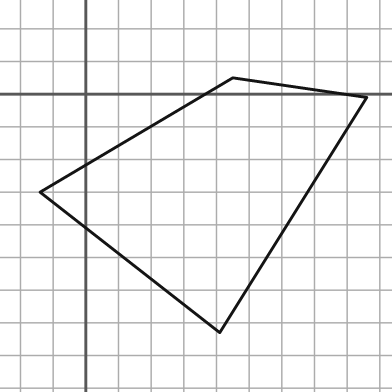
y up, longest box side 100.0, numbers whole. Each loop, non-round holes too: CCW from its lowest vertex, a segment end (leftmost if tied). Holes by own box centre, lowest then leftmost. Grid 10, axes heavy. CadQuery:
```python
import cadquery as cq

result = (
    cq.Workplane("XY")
    .moveTo(41.0, -73.0)
    .lineTo(86.0, -1.0)
    .lineTo(45.0, 5.0)
    .lineTo(-14.0, -30.0)
    .close()
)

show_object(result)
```